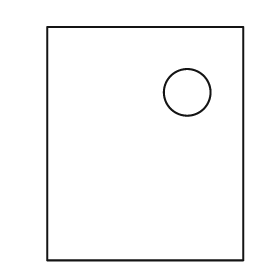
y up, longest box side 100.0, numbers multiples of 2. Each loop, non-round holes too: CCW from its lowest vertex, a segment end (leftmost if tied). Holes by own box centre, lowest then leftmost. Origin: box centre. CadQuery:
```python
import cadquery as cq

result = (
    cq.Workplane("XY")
    .moveTo(-42.0, -50.0)
    .lineTo(42.0, -50.0)
    .lineTo(42.0, 50.0)
    .lineTo(-42.0, 50.0)
    .close()
    .moveTo(18.0, 22.0)
    .circle(10.0)
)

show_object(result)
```